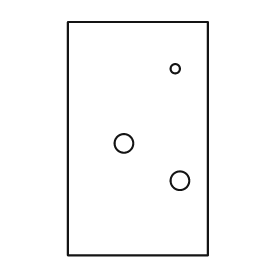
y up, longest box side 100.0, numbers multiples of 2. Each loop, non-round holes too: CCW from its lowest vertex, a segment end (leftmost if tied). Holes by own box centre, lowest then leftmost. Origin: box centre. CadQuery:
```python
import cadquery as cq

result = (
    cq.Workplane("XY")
    .moveTo(-30.0, -50.0)
    .lineTo(30.0, -50.0)
    .lineTo(30.0, 50.0)
    .lineTo(-30.0, 50.0)
    .close()
    .moveTo(18.0, -18.0)
    .circle(4.0)
    .moveTo(-6.0, -2.0)
    .circle(4.0)
    .moveTo(16.0, 30.0)
    .circle(2.0)
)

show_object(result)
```